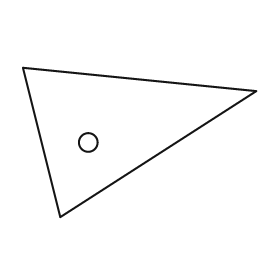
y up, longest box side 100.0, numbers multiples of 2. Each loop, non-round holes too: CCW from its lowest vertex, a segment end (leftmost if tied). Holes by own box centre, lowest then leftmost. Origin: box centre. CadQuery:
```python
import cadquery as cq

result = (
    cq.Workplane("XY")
    .moveTo(-34.0, -32.0)
    .lineTo(50.0, 22.0)
    .lineTo(-50.0, 32.0)
    .close()
    .moveTo(-22.0, 0.0)
    .circle(4.0)
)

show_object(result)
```